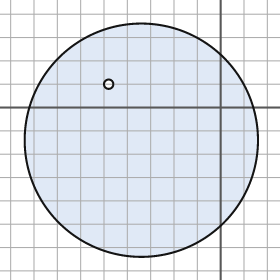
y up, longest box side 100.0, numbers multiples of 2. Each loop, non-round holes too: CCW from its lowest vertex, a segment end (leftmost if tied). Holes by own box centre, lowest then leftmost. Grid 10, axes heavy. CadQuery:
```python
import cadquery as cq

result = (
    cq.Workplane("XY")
    .moveTo(-34.0, -14.0)
    .circle(50.0)
    .moveTo(-48.0, 10.0)
    .circle(2.0)
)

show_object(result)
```